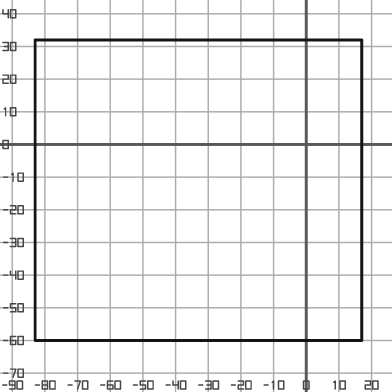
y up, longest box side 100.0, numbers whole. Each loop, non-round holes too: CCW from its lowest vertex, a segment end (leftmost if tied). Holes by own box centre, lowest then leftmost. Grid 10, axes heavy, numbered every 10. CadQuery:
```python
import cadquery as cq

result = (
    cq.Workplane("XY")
    .moveTo(-83.0, -60.0)
    .lineTo(17.0, -60.0)
    .lineTo(17.0, 32.0)
    .lineTo(-83.0, 32.0)
    .close()
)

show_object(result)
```